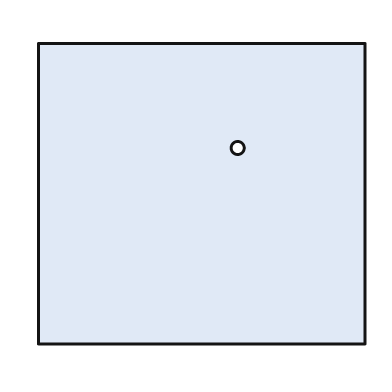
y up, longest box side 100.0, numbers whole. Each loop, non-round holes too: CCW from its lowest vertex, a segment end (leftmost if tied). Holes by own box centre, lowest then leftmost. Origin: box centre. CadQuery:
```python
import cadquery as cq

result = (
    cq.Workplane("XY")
    .moveTo(-50.0, -46.0)
    .lineTo(50.0, -46.0)
    .lineTo(50.0, 46.0)
    .lineTo(-50.0, 46.0)
    .close()
    .moveTo(11.0, 14.0)
    .circle(2.0)
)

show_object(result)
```